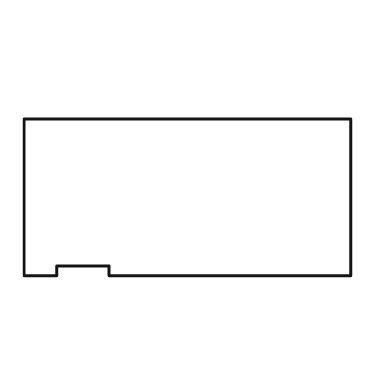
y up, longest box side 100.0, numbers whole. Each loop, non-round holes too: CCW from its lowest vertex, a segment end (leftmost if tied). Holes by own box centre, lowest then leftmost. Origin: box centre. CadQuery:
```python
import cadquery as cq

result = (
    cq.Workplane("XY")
    .moveTo(-50.0, -24.0)
    .lineTo(-40.0, -24.0)
    .lineTo(-40.0, -21.0)
    .lineTo(-24.0, -21.0)
    .lineTo(-24.0, -24.0)
    .lineTo(50.0, -24.0)
    .lineTo(50.0, 24.0)
    .lineTo(-50.0, 24.0)
    .close()
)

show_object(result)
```